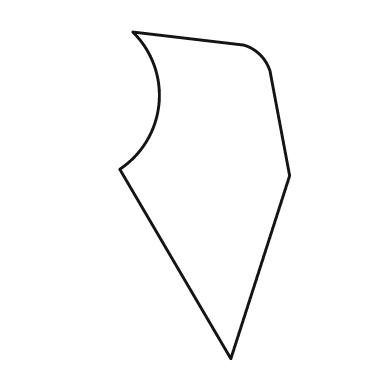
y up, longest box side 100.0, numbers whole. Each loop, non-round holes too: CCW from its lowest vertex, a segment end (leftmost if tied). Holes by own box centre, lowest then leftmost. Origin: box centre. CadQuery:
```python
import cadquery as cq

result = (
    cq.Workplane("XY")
    .moveTo(8.0, -50.0)
    .lineTo(26.0, 6.0)
    .lineTo(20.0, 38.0)
    .threePointArc((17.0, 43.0), (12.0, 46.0))
    .lineTo(-22.0, 50.0)
    .threePointArc((-14.0, 28.0), (-26.0, 8.0))
    .close()
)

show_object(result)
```